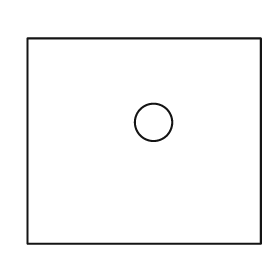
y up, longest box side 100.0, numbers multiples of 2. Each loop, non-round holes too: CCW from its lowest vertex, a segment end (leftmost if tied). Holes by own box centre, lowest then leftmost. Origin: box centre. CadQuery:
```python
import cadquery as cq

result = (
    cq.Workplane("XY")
    .moveTo(-50.0, -44.0)
    .lineTo(50.0, -44.0)
    .lineTo(50.0, 44.0)
    .lineTo(-50.0, 44.0)
    .close()
    .moveTo(4.0, 8.0)
    .circle(8.0)
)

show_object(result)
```